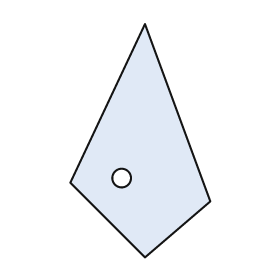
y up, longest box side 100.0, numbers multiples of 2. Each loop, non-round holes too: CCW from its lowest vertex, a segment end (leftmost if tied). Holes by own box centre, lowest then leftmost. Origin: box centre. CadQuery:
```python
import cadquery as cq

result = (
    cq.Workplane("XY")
    .moveTo(2.0, -50.0)
    .lineTo(30.0, -26.0)
    .lineTo(2.0, 50.0)
    .lineTo(-30.0, -18.0)
    .close()
    .moveTo(-8.0, -16.0)
    .circle(4.0)
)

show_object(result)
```